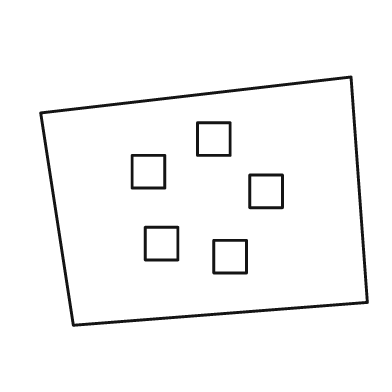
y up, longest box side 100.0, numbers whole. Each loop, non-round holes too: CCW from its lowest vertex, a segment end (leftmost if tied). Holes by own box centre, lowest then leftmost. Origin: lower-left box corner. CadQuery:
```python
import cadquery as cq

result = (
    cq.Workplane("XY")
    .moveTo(10.0, 0.0)
    .lineTo(100.0, 7.0)
    .lineTo(95.0, 76.0)
    .lineTo(0.0, 65.0)
    .close()
    .moveTo(53.0, 16.0)
    .lineTo(63.0, 16.0)
    .lineTo(63.0, 26.0)
    .lineTo(53.0, 26.0)
    .close()
    .moveTo(32.0, 20.0)
    .lineTo(42.0, 20.0)
    .lineTo(42.0, 30.0)
    .lineTo(32.0, 30.0)
    .close()
    .moveTo(64.0, 36.0)
    .lineTo(74.0, 36.0)
    .lineTo(74.0, 46.0)
    .lineTo(64.0, 46.0)
    .close()
    .moveTo(28.0, 42.0)
    .lineTo(38.0, 42.0)
    .lineTo(38.0, 52.0)
    .lineTo(28.0, 52.0)
    .close()
    .moveTo(48.0, 52.0)
    .lineTo(58.0, 52.0)
    .lineTo(58.0, 62.0)
    .lineTo(48.0, 62.0)
    .close()
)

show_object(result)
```